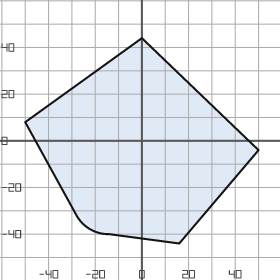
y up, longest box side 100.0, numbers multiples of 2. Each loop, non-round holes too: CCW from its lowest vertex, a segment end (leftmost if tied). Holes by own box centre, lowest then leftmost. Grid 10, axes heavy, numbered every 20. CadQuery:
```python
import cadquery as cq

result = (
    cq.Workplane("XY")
    .moveTo(16.0, -44.0)
    .lineTo(50.0, -4.0)
    .lineTo(0.0, 44.0)
    .lineTo(-50.0, 8.0)
    .lineTo(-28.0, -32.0)
    .threePointArc((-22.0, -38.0), (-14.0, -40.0))
    .close()
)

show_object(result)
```